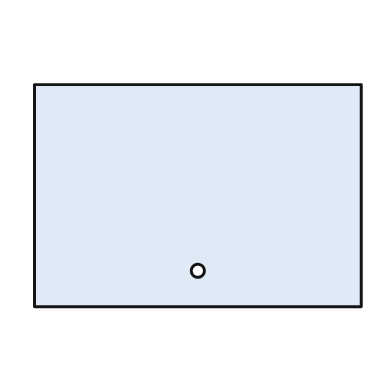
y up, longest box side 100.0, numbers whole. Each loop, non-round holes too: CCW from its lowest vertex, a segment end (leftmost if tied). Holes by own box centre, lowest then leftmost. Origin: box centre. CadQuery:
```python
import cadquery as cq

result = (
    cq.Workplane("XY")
    .moveTo(-50.0, -34.0)
    .lineTo(50.0, -34.0)
    .lineTo(50.0, 34.0)
    .lineTo(-50.0, 34.0)
    .close()
    .moveTo(0.0, -23.0)
    .circle(2.0)
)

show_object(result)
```